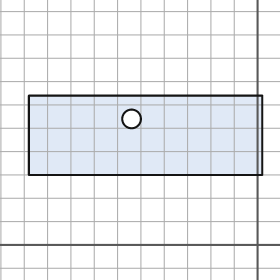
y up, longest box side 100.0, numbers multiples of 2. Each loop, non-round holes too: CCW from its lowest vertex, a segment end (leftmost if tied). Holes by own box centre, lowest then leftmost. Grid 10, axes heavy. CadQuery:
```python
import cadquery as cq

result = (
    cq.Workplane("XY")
    .moveTo(-98.0, 30.0)
    .lineTo(2.0, 30.0)
    .lineTo(2.0, 64.0)
    .lineTo(-98.0, 64.0)
    .close()
    .moveTo(-54.0, 54.0)
    .circle(4.0)
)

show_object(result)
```